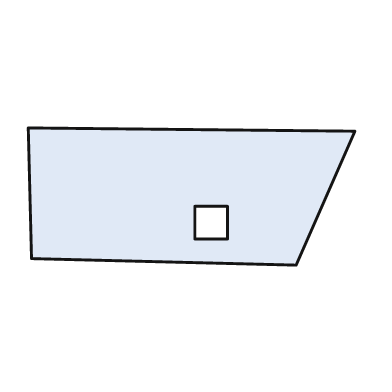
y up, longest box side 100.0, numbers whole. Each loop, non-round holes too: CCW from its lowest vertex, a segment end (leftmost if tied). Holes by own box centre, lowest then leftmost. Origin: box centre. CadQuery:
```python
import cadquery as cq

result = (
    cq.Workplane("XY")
    .moveTo(32.0, -21.0)
    .lineTo(50.0, 20.0)
    .lineTo(-50.0, 21.0)
    .lineTo(-49.0, -19.0)
    .close()
    .moveTo(1.0, -13.0)
    .lineTo(11.0, -13.0)
    .lineTo(11.0, -3.0)
    .lineTo(1.0, -3.0)
    .close()
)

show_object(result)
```